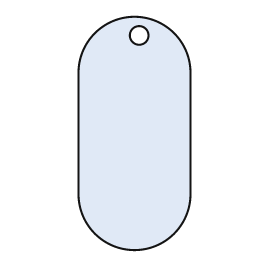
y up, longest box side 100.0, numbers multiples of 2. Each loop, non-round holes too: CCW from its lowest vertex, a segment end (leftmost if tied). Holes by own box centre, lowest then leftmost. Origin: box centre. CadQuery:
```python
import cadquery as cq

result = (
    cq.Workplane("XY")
    .moveTo(-24.0, -26.0)
    .threePointArc((0.0, -50.0), (24.0, -26.0))
    .lineTo(24.0, 26.0)
    .threePointArc((0.0, 50.0), (-24.0, 26.0))
    .close()
    .moveTo(2.0, 42.0)
    .circle(4.0)
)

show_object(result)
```